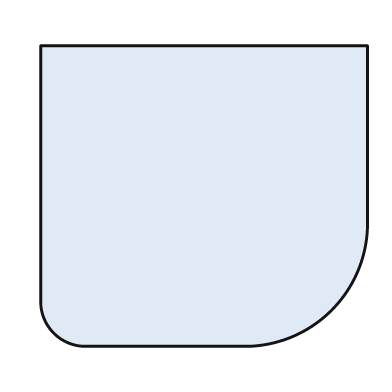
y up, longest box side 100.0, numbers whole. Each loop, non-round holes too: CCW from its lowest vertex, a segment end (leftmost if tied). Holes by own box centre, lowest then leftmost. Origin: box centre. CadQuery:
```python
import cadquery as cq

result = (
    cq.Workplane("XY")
    .moveTo(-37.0, -46.0)
    .lineTo(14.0, -46.0)
    .threePointArc((39.0, -35.0), (50.0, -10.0))
    .lineTo(50.0, 46.0)
    .lineTo(-50.0, 46.0)
    .lineTo(-50.0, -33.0)
    .threePointArc((-46.0, -42.0), (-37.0, -46.0))
    .close()
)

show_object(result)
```